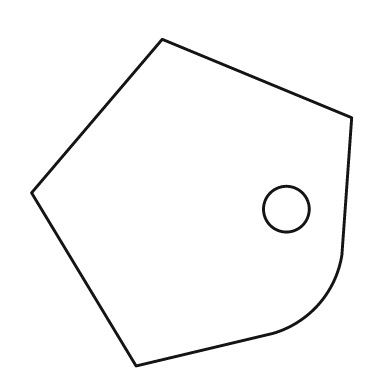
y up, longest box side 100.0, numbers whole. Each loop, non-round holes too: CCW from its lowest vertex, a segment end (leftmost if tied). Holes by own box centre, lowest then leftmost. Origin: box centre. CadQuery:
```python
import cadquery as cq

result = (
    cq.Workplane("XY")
    .moveTo(-17.0, -50.0)
    .lineTo(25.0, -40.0)
    .threePointArc((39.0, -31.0), (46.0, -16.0))
    .lineTo(49.0, 26.0)
    .lineTo(-9.0, 50.0)
    .lineTo(-49.0, 3.0)
    .close()
    .moveTo(29.0, -2.0)
    .circle(7.0)
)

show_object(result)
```